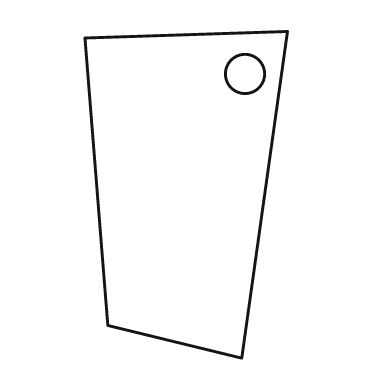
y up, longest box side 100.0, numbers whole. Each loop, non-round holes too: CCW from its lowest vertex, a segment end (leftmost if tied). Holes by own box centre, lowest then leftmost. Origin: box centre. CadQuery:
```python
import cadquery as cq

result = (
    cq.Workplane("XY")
    .moveTo(17.0, -50.0)
    .lineTo(31.0, 50.0)
    .lineTo(-31.0, 48.0)
    .lineTo(-24.0, -40.0)
    .close()
    .moveTo(18.0, 37.0)
    .circle(6.0)
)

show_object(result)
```